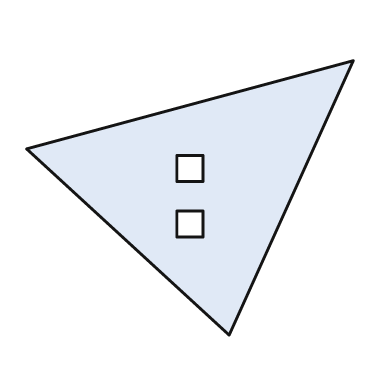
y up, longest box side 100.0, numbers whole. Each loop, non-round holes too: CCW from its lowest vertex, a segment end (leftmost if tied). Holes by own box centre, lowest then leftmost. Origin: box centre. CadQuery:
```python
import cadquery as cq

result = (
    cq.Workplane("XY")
    .moveTo(12.0, -42.0)
    .lineTo(50.0, 42.0)
    .lineTo(-50.0, 15.0)
    .close()
    .moveTo(-4.0, -12.0)
    .lineTo(4.0, -12.0)
    .lineTo(4.0, -4.0)
    .lineTo(-4.0, -4.0)
    .close()
    .moveTo(-4.0, 5.0)
    .lineTo(4.0, 5.0)
    .lineTo(4.0, 13.0)
    .lineTo(-4.0, 13.0)
    .close()
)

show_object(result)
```